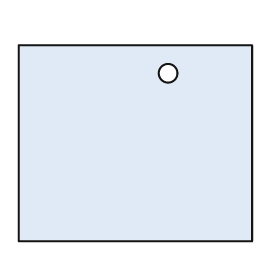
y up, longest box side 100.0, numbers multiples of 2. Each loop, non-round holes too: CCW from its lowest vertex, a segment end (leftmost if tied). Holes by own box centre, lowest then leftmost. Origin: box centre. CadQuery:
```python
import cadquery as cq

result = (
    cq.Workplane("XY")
    .moveTo(-50.0, -42.0)
    .lineTo(50.0, -42.0)
    .lineTo(50.0, 42.0)
    .lineTo(-50.0, 42.0)
    .close()
    .moveTo(14.0, 30.0)
    .circle(4.0)
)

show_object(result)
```